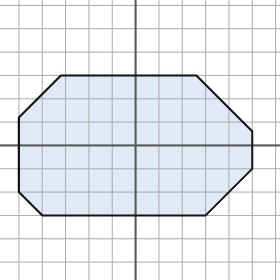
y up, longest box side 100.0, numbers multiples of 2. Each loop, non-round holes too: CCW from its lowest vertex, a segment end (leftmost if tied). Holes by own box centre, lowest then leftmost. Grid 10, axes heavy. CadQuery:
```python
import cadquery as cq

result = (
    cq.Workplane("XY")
    .moveTo(-40.0, -30.0)
    .lineTo(30.0, -30.0)
    .lineTo(50.0, -10.0)
    .lineTo(50.0, 6.0)
    .lineTo(26.0, 30.0)
    .lineTo(-32.0, 30.0)
    .lineTo(-50.0, 12.0)
    .lineTo(-50.0, -20.0)
    .close()
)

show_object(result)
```